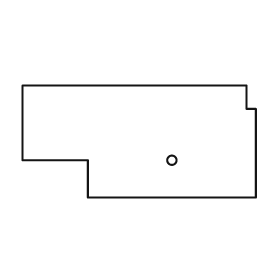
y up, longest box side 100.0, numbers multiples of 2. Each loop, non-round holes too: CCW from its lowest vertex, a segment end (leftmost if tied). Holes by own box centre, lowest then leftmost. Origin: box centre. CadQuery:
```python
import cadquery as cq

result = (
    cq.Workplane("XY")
    .moveTo(-22.0, -24.0)
    .lineTo(50.0, -24.0)
    .lineTo(50.0, 14.0)
    .lineTo(46.0, 14.0)
    .lineTo(46.0, 24.0)
    .lineTo(-50.0, 24.0)
    .lineTo(-50.0, -8.0)
    .lineTo(-22.0, -8.0)
    .close()
    .moveTo(14.0, -8.0)
    .circle(2.0)
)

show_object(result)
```